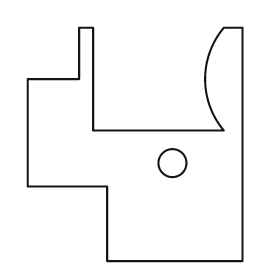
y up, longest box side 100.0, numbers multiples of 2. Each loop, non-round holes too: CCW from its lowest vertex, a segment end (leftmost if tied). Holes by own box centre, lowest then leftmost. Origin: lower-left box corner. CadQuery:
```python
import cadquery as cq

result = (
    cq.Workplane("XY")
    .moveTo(34.0, 0.0)
    .lineTo(92.0, 0.0)
    .lineTo(92.0, 100.0)
    .lineTo(84.0, 100.0)
    .threePointArc((76.0, 78.0), (84.0, 56.0))
    .lineTo(28.0, 56.0)
    .lineTo(28.0, 100.0)
    .lineTo(22.0, 100.0)
    .lineTo(22.0, 78.0)
    .lineTo(0.0, 78.0)
    .lineTo(0.0, 32.0)
    .lineTo(34.0, 32.0)
    .close()
    .moveTo(62.0, 42.0)
    .circle(6.0)
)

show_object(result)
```